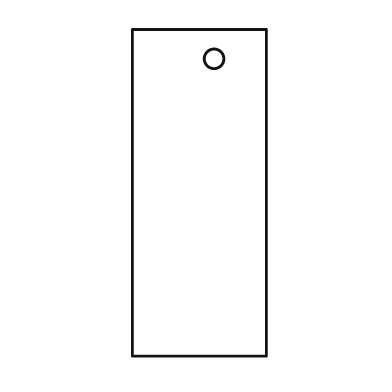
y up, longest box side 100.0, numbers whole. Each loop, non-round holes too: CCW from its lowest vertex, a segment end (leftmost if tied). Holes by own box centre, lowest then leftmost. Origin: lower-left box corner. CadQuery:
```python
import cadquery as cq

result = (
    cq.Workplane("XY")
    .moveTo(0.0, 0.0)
    .lineTo(41.0, 0.0)
    .lineTo(41.0, 100.0)
    .lineTo(0.0, 100.0)
    .close()
    .moveTo(25.0, 91.0)
    .circle(3.0)
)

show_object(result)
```